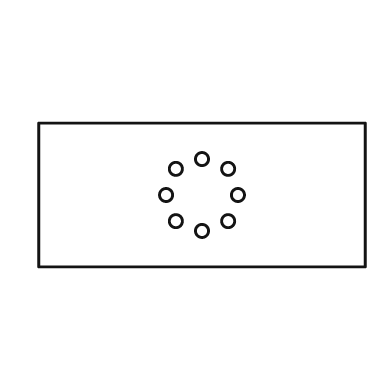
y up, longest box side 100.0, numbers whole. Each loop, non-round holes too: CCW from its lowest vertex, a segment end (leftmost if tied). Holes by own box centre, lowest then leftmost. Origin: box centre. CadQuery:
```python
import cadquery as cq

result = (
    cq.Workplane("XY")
    .moveTo(-50.0, -22.0)
    .lineTo(50.0, -22.0)
    .lineTo(50.0, 22.0)
    .lineTo(-50.0, 22.0)
    .close()
    .moveTo(0.0, -11.0)
    .circle(2.0)
    .moveTo(-8.0, -8.0)
    .circle(2.0)
    .moveTo(8.0, -8.0)
    .circle(2.0)
    .moveTo(-11.0, 0.0)
    .circle(2.0)
    .moveTo(11.0, 0.0)
    .circle(2.0)
    .moveTo(-8.0, 8.0)
    .circle(2.0)
    .moveTo(8.0, 8.0)
    .circle(2.0)
    .moveTo(0.0, 11.0)
    .circle(2.0)
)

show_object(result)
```